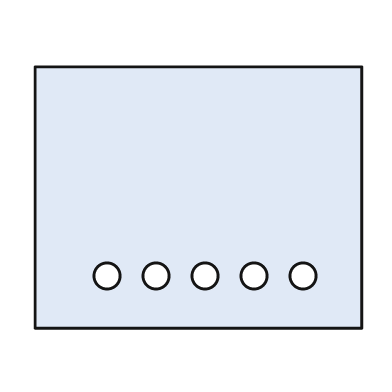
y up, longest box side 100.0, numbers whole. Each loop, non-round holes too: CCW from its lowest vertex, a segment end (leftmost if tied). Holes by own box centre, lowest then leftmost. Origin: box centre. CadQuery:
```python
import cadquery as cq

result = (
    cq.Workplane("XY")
    .moveTo(-50.0, -40.0)
    .lineTo(50.0, -40.0)
    .lineTo(50.0, 40.0)
    .lineTo(-50.0, 40.0)
    .close()
    .moveTo(-28.0, -24.0)
    .circle(4.0)
    .moveTo(-13.0, -24.0)
    .circle(4.0)
    .moveTo(2.0, -24.0)
    .circle(4.0)
    .moveTo(17.0, -24.0)
    .circle(4.0)
    .moveTo(32.0, -24.0)
    .circle(4.0)
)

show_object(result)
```